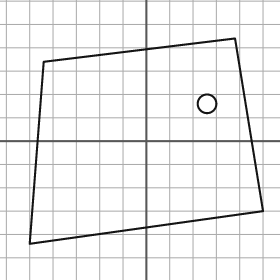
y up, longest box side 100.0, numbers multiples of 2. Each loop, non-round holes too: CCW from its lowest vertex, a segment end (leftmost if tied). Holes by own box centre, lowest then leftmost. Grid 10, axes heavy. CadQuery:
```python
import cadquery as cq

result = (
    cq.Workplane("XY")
    .moveTo(-50.0, -44.0)
    .lineTo(50.0, -30.0)
    .lineTo(38.0, 44.0)
    .lineTo(-44.0, 34.0)
    .close()
    .moveTo(26.0, 16.0)
    .circle(4.0)
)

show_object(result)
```